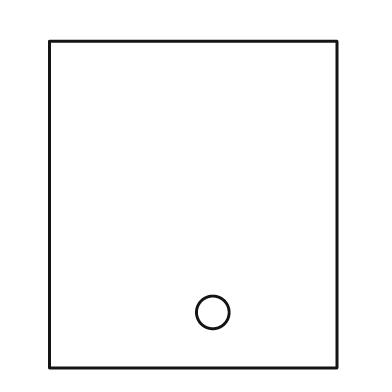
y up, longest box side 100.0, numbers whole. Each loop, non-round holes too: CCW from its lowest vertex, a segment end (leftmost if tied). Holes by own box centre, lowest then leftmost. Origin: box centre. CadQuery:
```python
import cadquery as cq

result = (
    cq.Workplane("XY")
    .moveTo(-44.0, -50.0)
    .lineTo(44.0, -50.0)
    .lineTo(44.0, 50.0)
    .lineTo(-44.0, 50.0)
    .close()
    .moveTo(6.0, -33.0)
    .circle(5.0)
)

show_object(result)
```